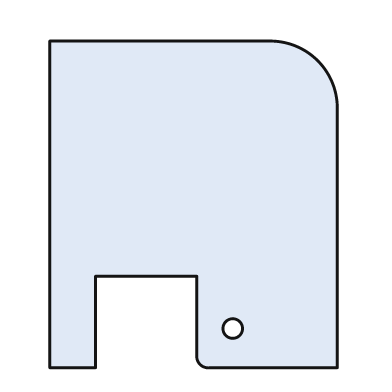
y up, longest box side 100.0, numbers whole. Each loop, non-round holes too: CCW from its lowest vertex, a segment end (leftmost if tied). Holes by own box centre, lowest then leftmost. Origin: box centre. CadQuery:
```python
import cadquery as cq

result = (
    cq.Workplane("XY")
    .moveTo(-44.0, -50.0)
    .lineTo(-30.0, -50.0)
    .lineTo(-30.0, -22.0)
    .lineTo(1.0, -22.0)
    .lineTo(1.0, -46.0)
    .threePointArc((2.0, -49.0), (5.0, -50.0))
    .lineTo(44.0, -50.0)
    .lineTo(44.0, 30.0)
    .threePointArc((38.0, 44.0), (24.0, 50.0))
    .lineTo(-44.0, 50.0)
    .close()
    .moveTo(12.0, -38.0)
    .circle(3.0)
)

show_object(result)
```